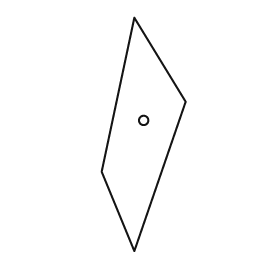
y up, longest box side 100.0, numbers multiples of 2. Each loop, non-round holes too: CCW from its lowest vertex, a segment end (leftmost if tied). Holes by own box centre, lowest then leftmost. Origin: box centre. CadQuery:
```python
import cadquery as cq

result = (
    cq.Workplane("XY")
    .moveTo(-4.0, -50.0)
    .lineTo(18.0, 14.0)
    .lineTo(-4.0, 50.0)
    .lineTo(-18.0, -16.0)
    .close()
    .moveTo(0.0, 6.0)
    .circle(2.0)
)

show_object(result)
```